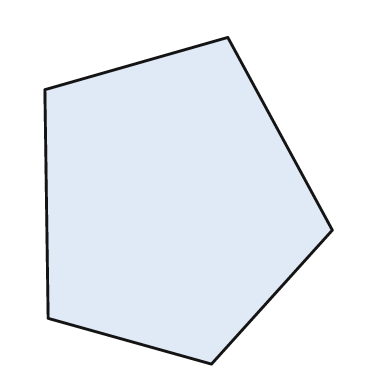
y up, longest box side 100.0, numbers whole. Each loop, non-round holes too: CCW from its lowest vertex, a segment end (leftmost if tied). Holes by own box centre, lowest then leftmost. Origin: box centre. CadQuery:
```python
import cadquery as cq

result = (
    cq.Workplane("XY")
    .moveTo(7.0, -50.0)
    .lineTo(44.0, -9.0)
    .lineTo(12.0, 50.0)
    .lineTo(-44.0, 34.0)
    .lineTo(-43.0, -36.0)
    .close()
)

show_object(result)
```